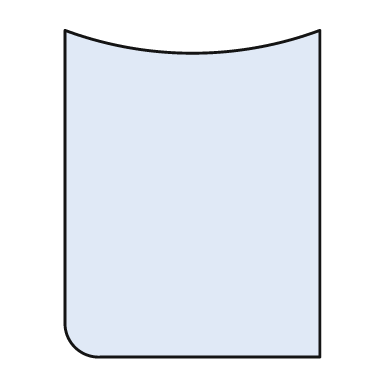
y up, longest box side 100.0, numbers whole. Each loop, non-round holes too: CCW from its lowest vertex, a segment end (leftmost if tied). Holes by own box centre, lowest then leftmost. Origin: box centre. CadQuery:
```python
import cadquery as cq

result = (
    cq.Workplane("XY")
    .moveTo(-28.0, -50.0)
    .lineTo(39.0, -50.0)
    .lineTo(39.0, 50.0)
    .threePointArc((0.0, 43.0), (-39.0, 50.0))
    .lineTo(-39.0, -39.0)
    .threePointArc((-36.0, -47.0), (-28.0, -50.0))
    .close()
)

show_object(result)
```